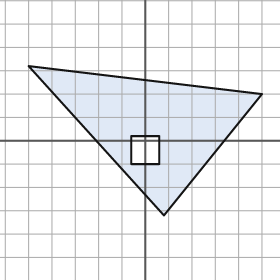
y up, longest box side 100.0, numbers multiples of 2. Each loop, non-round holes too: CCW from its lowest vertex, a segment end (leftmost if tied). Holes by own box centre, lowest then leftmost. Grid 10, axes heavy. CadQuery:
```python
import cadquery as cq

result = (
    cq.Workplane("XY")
    .moveTo(8.0, -32.0)
    .lineTo(50.0, 20.0)
    .lineTo(-50.0, 32.0)
    .close()
    .moveTo(-6.0, -10.0)
    .lineTo(6.0, -10.0)
    .lineTo(6.0, 2.0)
    .lineTo(-6.0, 2.0)
    .close()
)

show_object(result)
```